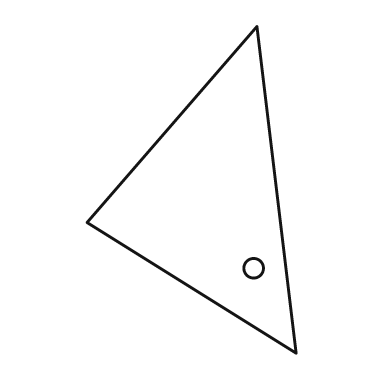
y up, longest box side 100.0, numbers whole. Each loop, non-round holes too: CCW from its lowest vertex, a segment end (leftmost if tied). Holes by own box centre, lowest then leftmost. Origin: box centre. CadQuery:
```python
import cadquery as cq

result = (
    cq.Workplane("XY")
    .moveTo(32.0, -50.0)
    .lineTo(20.0, 50.0)
    .lineTo(-32.0, -10.0)
    .close()
    .moveTo(19.0, -24.0)
    .circle(3.0)
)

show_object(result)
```